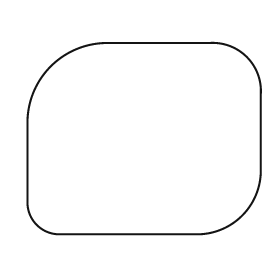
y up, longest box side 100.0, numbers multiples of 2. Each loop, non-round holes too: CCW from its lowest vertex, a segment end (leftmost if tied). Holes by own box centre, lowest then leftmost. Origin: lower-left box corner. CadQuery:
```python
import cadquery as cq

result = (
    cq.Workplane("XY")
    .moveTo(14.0, 0.0)
    .lineTo(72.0, 0.0)
    .threePointArc((92.0, 8.0), (100.0, 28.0))
    .lineTo(100.0, 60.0)
    .threePointArc((94.0, 76.0), (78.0, 82.0))
    .lineTo(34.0, 82.0)
    .threePointArc((10.0, 72.0), (0.0, 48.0))
    .lineTo(0.0, 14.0)
    .threePointArc((4.0, 4.0), (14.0, 0.0))
    .close()
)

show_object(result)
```